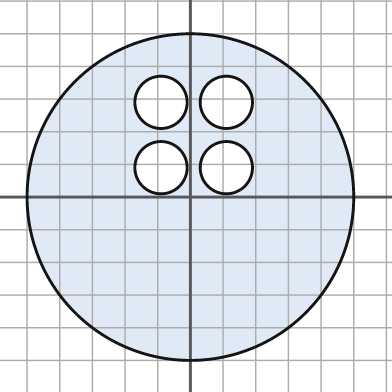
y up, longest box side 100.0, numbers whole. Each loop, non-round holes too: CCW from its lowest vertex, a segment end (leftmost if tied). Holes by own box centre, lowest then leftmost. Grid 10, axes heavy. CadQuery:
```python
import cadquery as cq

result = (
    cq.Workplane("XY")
    .moveTo(0.0, 0.0)
    .circle(50.0)
    .moveTo(-9.0, 9.0)
    .circle(8.0)
    .moveTo(11.0, 9.0)
    .circle(8.0)
    .moveTo(-9.0, 29.0)
    .circle(8.0)
    .moveTo(11.0, 29.0)
    .circle(8.0)
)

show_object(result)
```